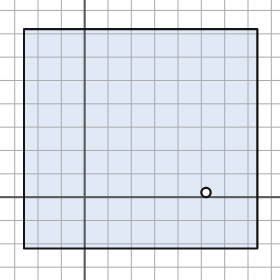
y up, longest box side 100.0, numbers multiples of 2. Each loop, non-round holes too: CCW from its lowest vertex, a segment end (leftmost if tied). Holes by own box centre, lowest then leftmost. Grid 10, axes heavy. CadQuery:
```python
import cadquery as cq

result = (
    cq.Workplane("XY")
    .moveTo(-26.0, -22.0)
    .lineTo(74.0, -22.0)
    .lineTo(74.0, 72.0)
    .lineTo(-26.0, 72.0)
    .close()
    .moveTo(52.0, 2.0)
    .circle(2.0)
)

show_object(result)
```